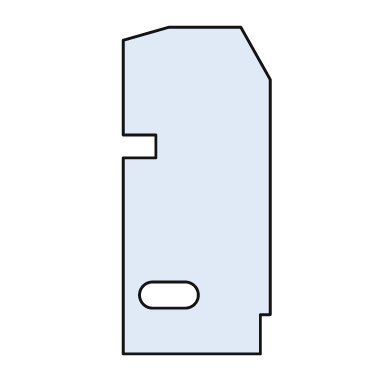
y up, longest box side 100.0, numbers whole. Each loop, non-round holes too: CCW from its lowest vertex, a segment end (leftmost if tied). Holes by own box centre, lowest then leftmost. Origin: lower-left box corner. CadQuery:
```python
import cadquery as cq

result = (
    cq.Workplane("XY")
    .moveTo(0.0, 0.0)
    .lineTo(42.0, 0.0)
    .lineTo(42.0, 12.0)
    .lineTo(45.0, 12.0)
    .lineTo(45.0, 84.0)
    .lineTo(36.0, 100.0)
    .lineTo(14.0, 100.0)
    .lineTo(0.0, 96.0)
    .lineTo(0.0, 67.0)
    .lineTo(10.0, 67.0)
    .lineTo(10.0, 60.0)
    .lineTo(0.0, 60.0)
    .close()
    .moveTo(9.0, 14.0)
    .lineTo(19.0, 14.0)
    .threePointArc((23.0, 18.0), (19.0, 22.0))
    .lineTo(9.0, 22.0)
    .threePointArc((5.0, 18.0), (9.0, 14.0))
    .close()
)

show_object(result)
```